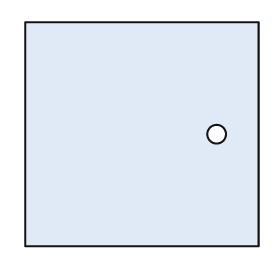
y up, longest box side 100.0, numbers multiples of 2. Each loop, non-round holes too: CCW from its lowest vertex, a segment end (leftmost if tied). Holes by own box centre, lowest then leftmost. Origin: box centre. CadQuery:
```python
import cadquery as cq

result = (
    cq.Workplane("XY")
    .moveTo(-50.0, -48.0)
    .lineTo(50.0, -48.0)
    .lineTo(50.0, 48.0)
    .lineTo(-50.0, 48.0)
    .close()
    .moveTo(32.0, 0.0)
    .circle(4.0)
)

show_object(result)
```